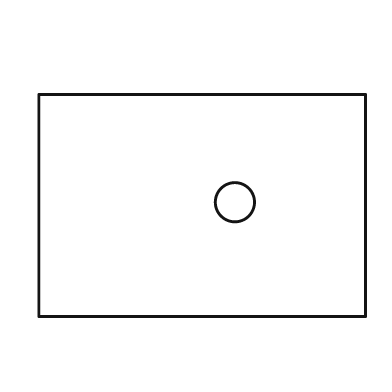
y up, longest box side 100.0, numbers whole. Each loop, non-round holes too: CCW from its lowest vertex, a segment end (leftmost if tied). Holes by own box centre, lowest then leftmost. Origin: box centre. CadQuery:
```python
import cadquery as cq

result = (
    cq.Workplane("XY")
    .moveTo(-50.0, -34.0)
    .lineTo(50.0, -34.0)
    .lineTo(50.0, 34.0)
    .lineTo(-50.0, 34.0)
    .close()
    .moveTo(10.0, 1.0)
    .circle(6.0)
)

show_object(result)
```